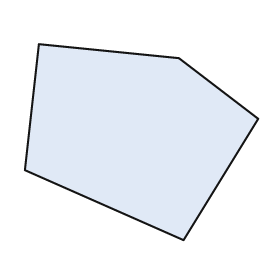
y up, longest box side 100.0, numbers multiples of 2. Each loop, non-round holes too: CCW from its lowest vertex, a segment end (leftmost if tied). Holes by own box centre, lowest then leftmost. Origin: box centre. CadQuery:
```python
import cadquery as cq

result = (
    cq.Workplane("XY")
    .moveTo(18.0, -42.0)
    .lineTo(50.0, 10.0)
    .lineTo(16.0, 36.0)
    .lineTo(-44.0, 42.0)
    .lineTo(-50.0, -12.0)
    .close()
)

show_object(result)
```